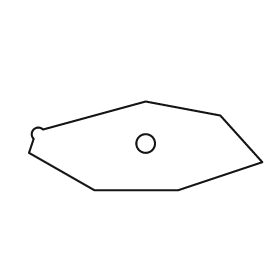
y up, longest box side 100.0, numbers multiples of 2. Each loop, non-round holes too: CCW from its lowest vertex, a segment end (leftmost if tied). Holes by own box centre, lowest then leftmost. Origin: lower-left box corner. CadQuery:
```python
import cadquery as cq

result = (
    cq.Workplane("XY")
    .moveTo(28.0, 0.0)
    .lineTo(64.0, 0.0)
    .lineTo(100.0, 12.0)
    .lineTo(82.0, 32.0)
    .lineTo(50.0, 38.0)
    .lineTo(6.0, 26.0)
    .threePointArc((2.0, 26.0), (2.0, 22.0))
    .lineTo(0.0, 16.0)
    .close()
    .moveTo(50.0, 20.0)
    .circle(4.0)
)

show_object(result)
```